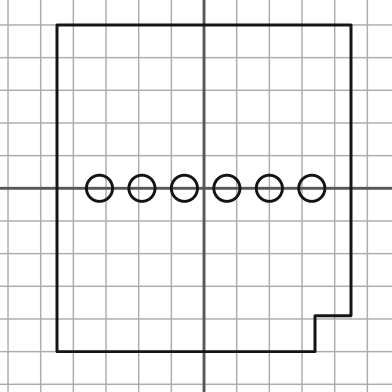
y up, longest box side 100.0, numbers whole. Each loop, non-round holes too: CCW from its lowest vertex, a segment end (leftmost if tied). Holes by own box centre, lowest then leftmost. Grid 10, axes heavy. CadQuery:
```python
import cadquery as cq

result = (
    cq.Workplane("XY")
    .moveTo(-45.0, -50.0)
    .lineTo(34.0, -50.0)
    .lineTo(34.0, -39.0)
    .lineTo(45.0, -39.0)
    .lineTo(45.0, 50.0)
    .lineTo(-45.0, 50.0)
    .close()
    .moveTo(-32.0, 0.0)
    .circle(4.0)
    .moveTo(-19.0, 0.0)
    .circle(4.0)
    .moveTo(-6.0, 0.0)
    .circle(4.0)
    .moveTo(7.0, 0.0)
    .circle(4.0)
    .moveTo(20.0, 0.0)
    .circle(4.0)
    .moveTo(33.0, 0.0)
    .circle(4.0)
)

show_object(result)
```